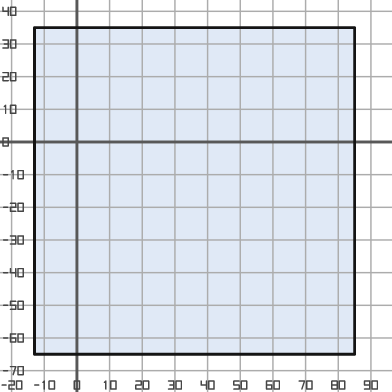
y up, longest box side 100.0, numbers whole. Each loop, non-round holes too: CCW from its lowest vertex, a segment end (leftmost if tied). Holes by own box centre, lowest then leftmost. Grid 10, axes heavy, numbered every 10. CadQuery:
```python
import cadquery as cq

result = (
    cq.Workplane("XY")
    .moveTo(-13.0, -65.0)
    .lineTo(85.0, -65.0)
    .lineTo(85.0, 35.0)
    .lineTo(-13.0, 35.0)
    .close()
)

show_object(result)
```